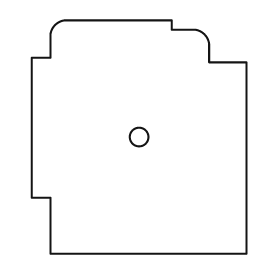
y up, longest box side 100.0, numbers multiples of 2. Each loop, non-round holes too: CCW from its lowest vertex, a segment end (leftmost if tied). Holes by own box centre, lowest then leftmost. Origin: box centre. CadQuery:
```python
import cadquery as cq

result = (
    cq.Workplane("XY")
    .moveTo(-38.0, -50.0)
    .lineTo(46.0, -50.0)
    .lineTo(46.0, 32.0)
    .lineTo(30.0, 32.0)
    .lineTo(30.0, 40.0)
    .threePointArc((28.0, 44.0), (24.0, 46.0))
    .lineTo(14.0, 46.0)
    .lineTo(14.0, 50.0)
    .lineTo(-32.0, 50.0)
    .threePointArc((-36.0, 48.0), (-38.0, 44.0))
    .lineTo(-38.0, 34.0)
    .lineTo(-46.0, 34.0)
    .lineTo(-46.0, -26.0)
    .lineTo(-38.0, -26.0)
    .close()
    .moveTo(0.0, 0.0)
    .circle(4.0)
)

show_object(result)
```